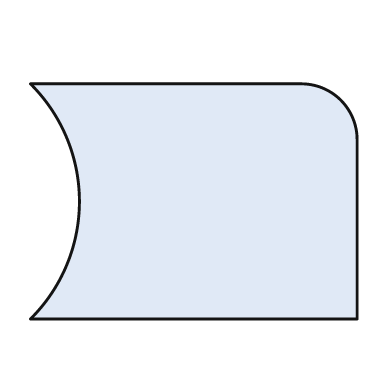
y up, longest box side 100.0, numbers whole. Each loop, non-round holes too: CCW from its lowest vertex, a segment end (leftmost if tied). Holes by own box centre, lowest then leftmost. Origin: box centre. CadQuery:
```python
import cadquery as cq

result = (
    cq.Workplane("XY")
    .moveTo(-50.0, -36.0)
    .lineTo(50.0, -36.0)
    .lineTo(50.0, 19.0)
    .threePointArc((45.0, 31.0), (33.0, 36.0))
    .lineTo(-50.0, 36.0)
    .threePointArc((-35.0, 0.0), (-50.0, -36.0))
    .close()
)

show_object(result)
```